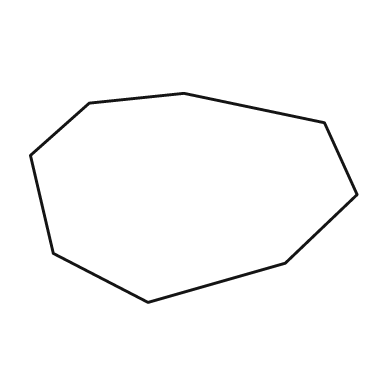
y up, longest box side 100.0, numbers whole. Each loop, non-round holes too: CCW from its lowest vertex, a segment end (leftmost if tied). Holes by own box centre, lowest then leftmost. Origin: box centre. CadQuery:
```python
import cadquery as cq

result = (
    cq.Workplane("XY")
    .moveTo(-14.0, -32.0)
    .lineTo(28.0, -20.0)
    .lineTo(50.0, 1.0)
    .lineTo(40.0, 23.0)
    .lineTo(-3.0, 32.0)
    .lineTo(-32.0, 29.0)
    .lineTo(-50.0, 13.0)
    .lineTo(-43.0, -17.0)
    .close()
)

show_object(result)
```